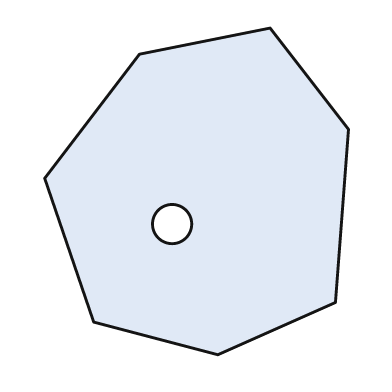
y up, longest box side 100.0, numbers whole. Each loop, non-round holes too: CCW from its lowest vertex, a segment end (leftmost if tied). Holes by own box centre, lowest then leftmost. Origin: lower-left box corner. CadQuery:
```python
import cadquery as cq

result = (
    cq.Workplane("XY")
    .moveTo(53.0, 0.0)
    .lineTo(89.0, 16.0)
    .lineTo(93.0, 69.0)
    .lineTo(69.0, 100.0)
    .lineTo(29.0, 92.0)
    .lineTo(0.0, 54.0)
    .lineTo(15.0, 10.0)
    .close()
    .moveTo(39.0, 40.0)
    .circle(6.0)
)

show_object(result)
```